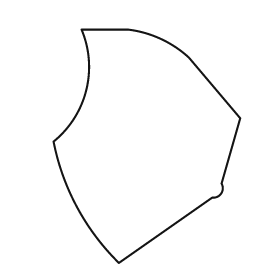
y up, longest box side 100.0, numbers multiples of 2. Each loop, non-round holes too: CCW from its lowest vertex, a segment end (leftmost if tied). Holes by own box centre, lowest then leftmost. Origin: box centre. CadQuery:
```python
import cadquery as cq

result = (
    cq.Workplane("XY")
    .moveTo(-12.0, -50.0)
    .lineTo(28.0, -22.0)
    .threePointArc((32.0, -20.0), (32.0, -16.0))
    .lineTo(40.0, 12.0)
    .lineTo(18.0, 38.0)
    .threePointArc((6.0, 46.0), (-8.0, 50.0))
    .lineTo(-28.0, 50.0)
    .threePointArc((-26.0, 24.0), (-40.0, 2.0))
    .threePointArc((-30.0, -26.0), (-12.0, -50.0))
    .close()
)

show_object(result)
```